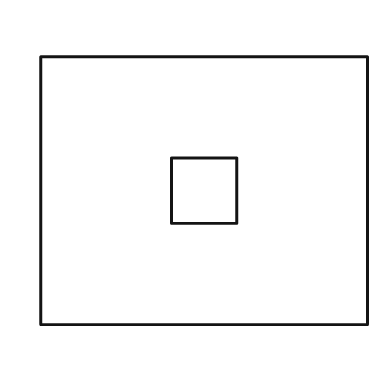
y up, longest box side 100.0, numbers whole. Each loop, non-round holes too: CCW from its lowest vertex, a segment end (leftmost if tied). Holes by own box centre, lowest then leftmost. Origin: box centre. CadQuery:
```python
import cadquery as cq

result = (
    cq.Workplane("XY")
    .moveTo(-50.0, -41.0)
    .lineTo(50.0, -41.0)
    .lineTo(50.0, 41.0)
    .lineTo(-50.0, 41.0)
    .close()
    .moveTo(-10.0, -10.0)
    .lineTo(10.0, -10.0)
    .lineTo(10.0, 10.0)
    .lineTo(-10.0, 10.0)
    .close()
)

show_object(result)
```